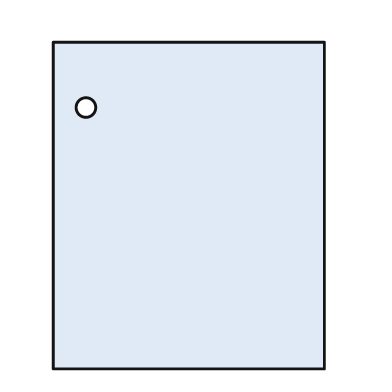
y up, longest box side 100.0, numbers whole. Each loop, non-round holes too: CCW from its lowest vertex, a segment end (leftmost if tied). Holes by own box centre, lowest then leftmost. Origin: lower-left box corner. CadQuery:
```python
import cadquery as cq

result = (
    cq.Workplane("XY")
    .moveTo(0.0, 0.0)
    .lineTo(83.0, 0.0)
    .lineTo(83.0, 100.0)
    .lineTo(0.0, 100.0)
    .close()
    .moveTo(10.0, 80.0)
    .circle(3.0)
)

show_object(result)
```